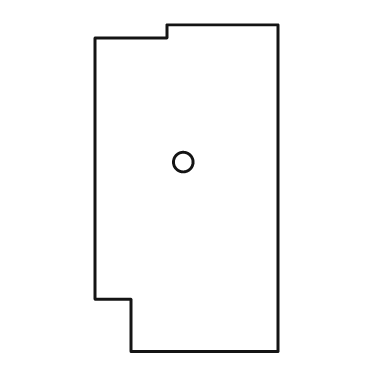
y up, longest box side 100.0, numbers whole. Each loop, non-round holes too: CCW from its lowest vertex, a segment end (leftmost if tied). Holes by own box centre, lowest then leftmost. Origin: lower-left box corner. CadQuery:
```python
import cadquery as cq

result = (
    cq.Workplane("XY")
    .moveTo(11.0, 0.0)
    .lineTo(56.0, 0.0)
    .lineTo(56.0, 100.0)
    .lineTo(22.0, 100.0)
    .lineTo(22.0, 96.0)
    .lineTo(0.0, 96.0)
    .lineTo(0.0, 16.0)
    .lineTo(11.0, 16.0)
    .close()
    .moveTo(27.0, 58.0)
    .circle(3.0)
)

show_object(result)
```